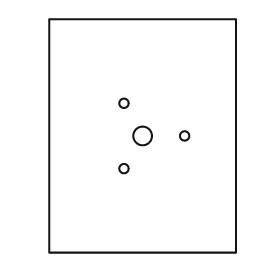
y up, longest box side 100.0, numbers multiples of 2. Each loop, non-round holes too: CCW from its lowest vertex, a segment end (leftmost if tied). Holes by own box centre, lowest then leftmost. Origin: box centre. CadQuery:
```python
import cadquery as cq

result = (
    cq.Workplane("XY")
    .moveTo(-40.0, -50.0)
    .lineTo(40.0, -50.0)
    .lineTo(40.0, 50.0)
    .lineTo(-40.0, 50.0)
    .close()
    .moveTo(-8.0, -14.0)
    .circle(2.0)
    .moveTo(0.0, 0.0)
    .circle(4.0)
    .moveTo(18.0, 0.0)
    .circle(2.0)
    .moveTo(-8.0, 14.0)
    .circle(2.0)
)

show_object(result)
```